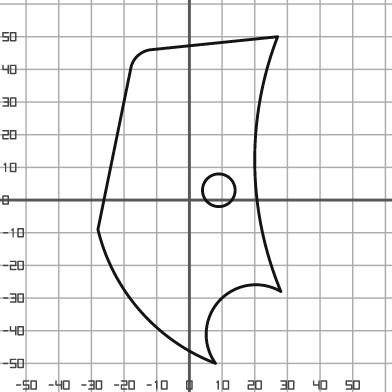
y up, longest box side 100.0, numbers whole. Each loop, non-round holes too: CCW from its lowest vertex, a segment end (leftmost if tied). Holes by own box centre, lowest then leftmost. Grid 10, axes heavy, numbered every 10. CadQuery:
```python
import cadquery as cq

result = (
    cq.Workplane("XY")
    .moveTo(8.0, -50.0)
    .threePointArc((9.0, -31.0), (28.0, -28.0))
    .threePointArc((20.0, 11.0), (27.0, 50.0))
    .lineTo(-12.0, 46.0)
    .threePointArc((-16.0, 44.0), (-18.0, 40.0))
    .lineTo(-28.0, -9.0)
    .threePointArc((-15.0, -34.0), (8.0, -50.0))
    .close()
    .moveTo(9.0, 3.0)
    .circle(5.0)
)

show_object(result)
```